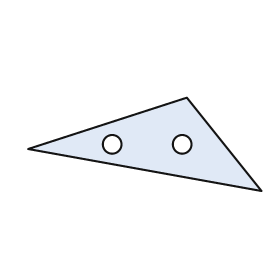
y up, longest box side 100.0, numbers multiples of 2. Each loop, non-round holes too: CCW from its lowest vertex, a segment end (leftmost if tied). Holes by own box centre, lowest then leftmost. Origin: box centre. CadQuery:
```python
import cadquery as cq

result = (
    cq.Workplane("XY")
    .moveTo(50.0, -20.0)
    .lineTo(18.0, 20.0)
    .lineTo(-50.0, -2.0)
    .close()
    .moveTo(-14.0, 0.0)
    .circle(4.0)
    .moveTo(16.0, 0.0)
    .circle(4.0)
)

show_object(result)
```